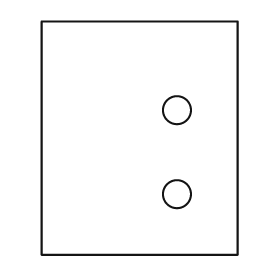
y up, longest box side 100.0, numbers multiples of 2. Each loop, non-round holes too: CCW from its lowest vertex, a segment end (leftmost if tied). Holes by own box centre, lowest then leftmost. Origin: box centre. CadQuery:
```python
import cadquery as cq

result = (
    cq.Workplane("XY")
    .moveTo(-42.0, -50.0)
    .lineTo(42.0, -50.0)
    .lineTo(42.0, 50.0)
    .lineTo(-42.0, 50.0)
    .close()
    .moveTo(16.0, -24.0)
    .circle(6.0)
    .moveTo(16.0, 12.0)
    .circle(6.0)
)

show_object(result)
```